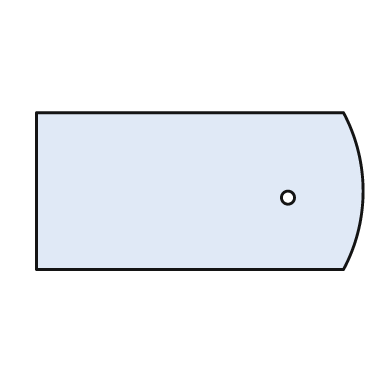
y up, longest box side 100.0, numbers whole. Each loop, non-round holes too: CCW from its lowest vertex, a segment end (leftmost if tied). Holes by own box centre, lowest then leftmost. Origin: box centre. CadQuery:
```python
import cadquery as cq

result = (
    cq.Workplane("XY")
    .moveTo(-50.0, -24.0)
    .lineTo(44.0, -24.0)
    .threePointArc((50.0, 0.0), (44.0, 24.0))
    .lineTo(-50.0, 24.0)
    .close()
    .moveTo(27.0, -2.0)
    .circle(2.0)
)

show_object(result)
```